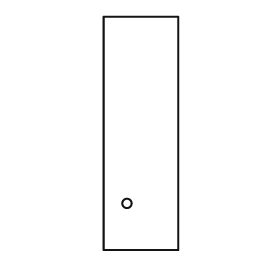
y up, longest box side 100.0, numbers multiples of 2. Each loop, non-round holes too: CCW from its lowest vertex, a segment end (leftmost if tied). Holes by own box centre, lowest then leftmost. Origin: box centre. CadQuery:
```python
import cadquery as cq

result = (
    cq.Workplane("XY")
    .moveTo(-16.0, -50.0)
    .lineTo(16.0, -50.0)
    .lineTo(16.0, 50.0)
    .lineTo(-16.0, 50.0)
    .close()
    .moveTo(-6.0, -30.0)
    .circle(2.0)
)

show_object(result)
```